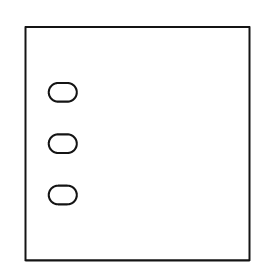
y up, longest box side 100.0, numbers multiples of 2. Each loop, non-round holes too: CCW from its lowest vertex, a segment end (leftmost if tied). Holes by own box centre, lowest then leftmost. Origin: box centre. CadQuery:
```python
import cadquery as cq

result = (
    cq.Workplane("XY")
    .moveTo(-48.0, -50.0)
    .lineTo(48.0, -50.0)
    .lineTo(48.0, 50.0)
    .lineTo(-48.0, 50.0)
    .close()
    .moveTo(-34.0, -26.0)
    .lineTo(-30.0, -26.0)
    .threePointArc((-26.0, -22.0), (-30.0, -18.0))
    .lineTo(-34.0, -18.0)
    .threePointArc((-38.0, -22.0), (-34.0, -26.0))
    .close()
    .moveTo(-34.0, -4.0)
    .lineTo(-30.0, -4.0)
    .threePointArc((-26.0, 0.0), (-30.0, 4.0))
    .lineTo(-34.0, 4.0)
    .threePointArc((-38.0, 0.0), (-34.0, -4.0))
    .close()
    .moveTo(-34.0, 18.0)
    .lineTo(-30.0, 18.0)
    .threePointArc((-26.0, 22.0), (-30.0, 26.0))
    .lineTo(-34.0, 26.0)
    .threePointArc((-38.0, 22.0), (-34.0, 18.0))
    .close()
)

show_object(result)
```